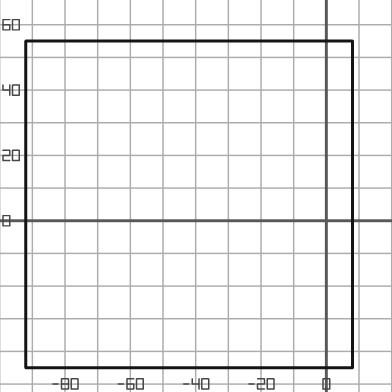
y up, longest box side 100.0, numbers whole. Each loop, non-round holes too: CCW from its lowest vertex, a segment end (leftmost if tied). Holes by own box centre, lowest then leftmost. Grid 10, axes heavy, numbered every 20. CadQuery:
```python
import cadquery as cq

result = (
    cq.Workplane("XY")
    .moveTo(-92.0, -45.0)
    .lineTo(8.0, -45.0)
    .lineTo(8.0, 55.0)
    .lineTo(-92.0, 55.0)
    .close()
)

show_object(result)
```